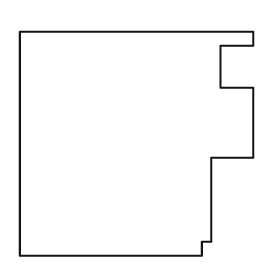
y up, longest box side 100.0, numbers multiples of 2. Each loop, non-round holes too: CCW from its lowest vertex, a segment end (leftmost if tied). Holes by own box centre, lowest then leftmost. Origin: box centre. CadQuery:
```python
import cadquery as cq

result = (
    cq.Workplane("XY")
    .moveTo(-50.0, -48.0)
    .lineTo(28.0, -48.0)
    .lineTo(28.0, -42.0)
    .lineTo(32.0, -42.0)
    .lineTo(32.0, -6.0)
    .lineTo(50.0, -6.0)
    .lineTo(50.0, 24.0)
    .lineTo(36.0, 24.0)
    .lineTo(36.0, 42.0)
    .lineTo(50.0, 42.0)
    .lineTo(50.0, 48.0)
    .lineTo(-50.0, 48.0)
    .close()
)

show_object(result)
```